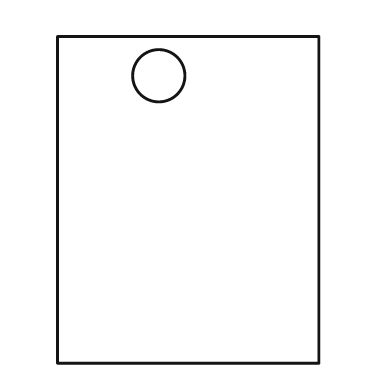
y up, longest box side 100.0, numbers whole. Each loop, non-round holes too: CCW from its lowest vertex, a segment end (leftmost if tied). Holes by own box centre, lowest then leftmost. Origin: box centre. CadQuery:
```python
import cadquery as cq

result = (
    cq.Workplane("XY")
    .moveTo(-40.0, -50.0)
    .lineTo(40.0, -50.0)
    .lineTo(40.0, 50.0)
    .lineTo(-40.0, 50.0)
    .close()
    .moveTo(-9.0, 38.0)
    .circle(8.0)
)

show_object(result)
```